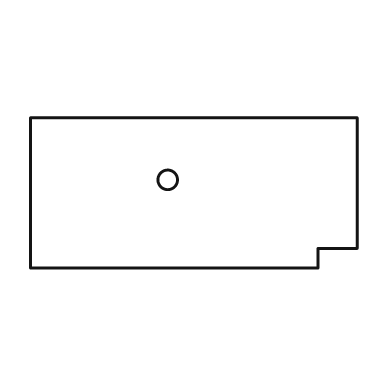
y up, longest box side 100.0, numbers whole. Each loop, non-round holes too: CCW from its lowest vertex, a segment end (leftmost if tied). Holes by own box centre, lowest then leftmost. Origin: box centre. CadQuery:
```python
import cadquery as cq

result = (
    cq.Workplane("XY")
    .moveTo(-50.0, -23.0)
    .lineTo(38.0, -23.0)
    .lineTo(38.0, -17.0)
    .lineTo(50.0, -17.0)
    .lineTo(50.0, 23.0)
    .lineTo(-50.0, 23.0)
    .close()
    .moveTo(-8.0, 4.0)
    .circle(3.0)
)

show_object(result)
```